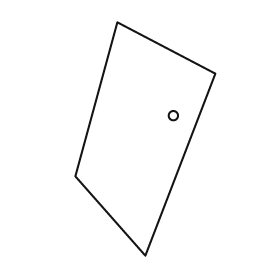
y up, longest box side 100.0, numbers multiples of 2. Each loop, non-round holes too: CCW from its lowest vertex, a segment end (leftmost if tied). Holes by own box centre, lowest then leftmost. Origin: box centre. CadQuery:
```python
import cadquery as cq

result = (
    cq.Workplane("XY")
    .moveTo(0.0, -50.0)
    .lineTo(30.0, 28.0)
    .lineTo(-12.0, 50.0)
    .lineTo(-30.0, -16.0)
    .close()
    .moveTo(12.0, 10.0)
    .circle(2.0)
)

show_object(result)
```